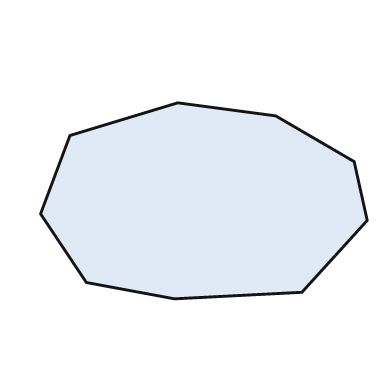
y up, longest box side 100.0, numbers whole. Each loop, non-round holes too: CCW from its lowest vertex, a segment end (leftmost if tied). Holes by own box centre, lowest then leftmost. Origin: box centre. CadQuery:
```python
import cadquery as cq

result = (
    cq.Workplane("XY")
    .moveTo(-9.0, -30.0)
    .lineTo(30.0, -28.0)
    .lineTo(50.0, -6.0)
    .lineTo(46.0, 12.0)
    .lineTo(22.0, 26.0)
    .lineTo(-8.0, 30.0)
    .lineTo(-41.0, 20.0)
    .lineTo(-50.0, -4.0)
    .lineTo(-36.0, -25.0)
    .close()
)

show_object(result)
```